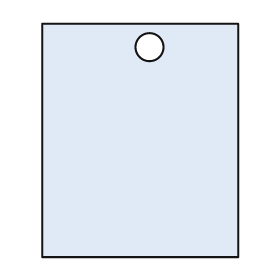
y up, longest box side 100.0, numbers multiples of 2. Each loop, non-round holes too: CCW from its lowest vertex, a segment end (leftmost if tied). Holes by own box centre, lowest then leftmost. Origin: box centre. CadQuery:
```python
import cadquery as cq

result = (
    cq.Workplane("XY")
    .moveTo(-42.0, -50.0)
    .lineTo(42.0, -50.0)
    .lineTo(42.0, 50.0)
    .lineTo(-42.0, 50.0)
    .close()
    .moveTo(4.0, 40.0)
    .circle(6.0)
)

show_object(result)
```